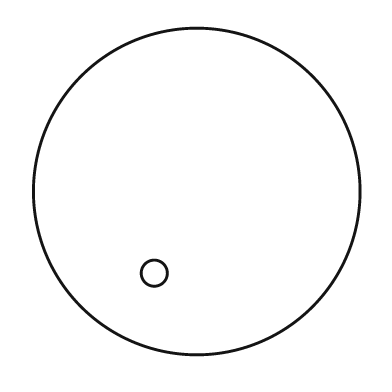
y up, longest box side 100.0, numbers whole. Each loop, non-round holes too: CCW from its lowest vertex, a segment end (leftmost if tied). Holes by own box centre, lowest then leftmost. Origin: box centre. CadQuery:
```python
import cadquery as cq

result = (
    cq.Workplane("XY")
    .moveTo(0.0, 0.0)
    .circle(50.0)
    .moveTo(-13.0, -25.0)
    .circle(4.0)
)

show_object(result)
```